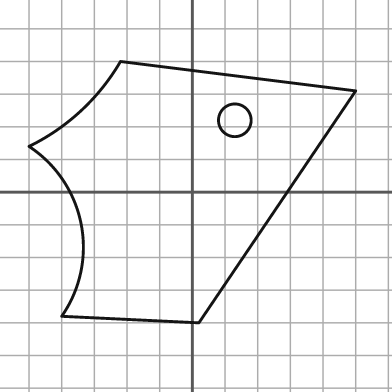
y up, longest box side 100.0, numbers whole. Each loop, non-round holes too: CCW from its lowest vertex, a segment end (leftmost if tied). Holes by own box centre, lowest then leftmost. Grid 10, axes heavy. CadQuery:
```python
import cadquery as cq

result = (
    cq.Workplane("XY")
    .moveTo(2.0, -40.0)
    .lineTo(50.0, 31.0)
    .lineTo(-22.0, 40.0)
    .threePointArc((-34.0, 25.0), (-50.0, 14.0))
    .threePointArc((-34.0, -10.0), (-40.0, -38.0))
    .close()
    .moveTo(13.0, 22.0)
    .circle(5.0)
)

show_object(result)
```